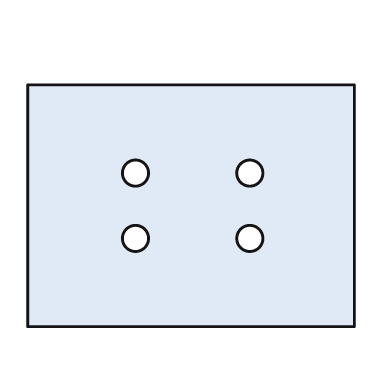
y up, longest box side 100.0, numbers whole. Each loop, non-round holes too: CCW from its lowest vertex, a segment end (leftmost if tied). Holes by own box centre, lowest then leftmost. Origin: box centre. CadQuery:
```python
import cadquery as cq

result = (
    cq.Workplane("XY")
    .moveTo(-50.0, -37.0)
    .lineTo(50.0, -37.0)
    .lineTo(50.0, 37.0)
    .lineTo(-50.0, 37.0)
    .close()
    .moveTo(-17.0, -10.0)
    .circle(4.0)
    .moveTo(18.0, -10.0)
    .circle(4.0)
    .moveTo(-17.0, 10.0)
    .circle(4.0)
    .moveTo(18.0, 10.0)
    .circle(4.0)
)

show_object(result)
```